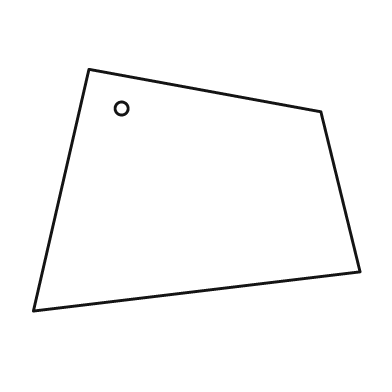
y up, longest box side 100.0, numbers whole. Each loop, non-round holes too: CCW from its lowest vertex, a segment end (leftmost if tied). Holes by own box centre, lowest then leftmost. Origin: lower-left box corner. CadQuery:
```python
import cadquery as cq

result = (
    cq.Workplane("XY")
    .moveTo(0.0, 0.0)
    .lineTo(100.0, 12.0)
    .lineTo(88.0, 61.0)
    .lineTo(17.0, 74.0)
    .close()
    .moveTo(27.0, 62.0)
    .circle(2.0)
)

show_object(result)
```